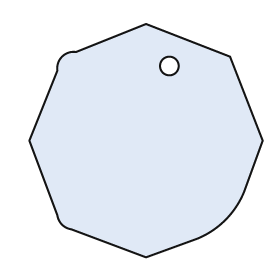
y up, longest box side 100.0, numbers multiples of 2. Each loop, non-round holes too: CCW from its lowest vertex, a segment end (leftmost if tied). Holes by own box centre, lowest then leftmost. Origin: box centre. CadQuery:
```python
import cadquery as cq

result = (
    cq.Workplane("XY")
    .moveTo(0.0, -50.0)
    .lineTo(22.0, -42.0)
    .threePointArc((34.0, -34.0), (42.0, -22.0))
    .lineTo(50.0, 0.0)
    .lineTo(36.0, 36.0)
    .lineTo(0.0, 50.0)
    .lineTo(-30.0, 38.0)
    .threePointArc((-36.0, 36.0), (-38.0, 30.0))
    .lineTo(-50.0, 0.0)
    .lineTo(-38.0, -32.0)
    .threePointArc((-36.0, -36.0), (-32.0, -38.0))
    .close()
    .moveTo(10.0, 32.0)
    .circle(4.0)
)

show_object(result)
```